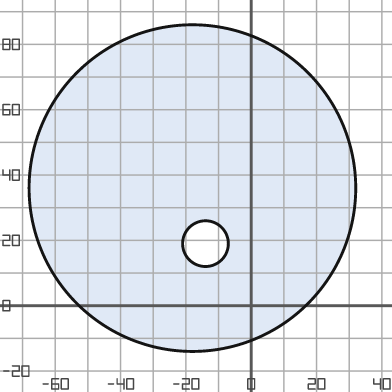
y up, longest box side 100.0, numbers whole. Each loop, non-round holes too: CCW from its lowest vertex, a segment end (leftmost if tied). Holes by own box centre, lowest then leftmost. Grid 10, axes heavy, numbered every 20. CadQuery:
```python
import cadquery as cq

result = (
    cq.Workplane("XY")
    .moveTo(-18.0, 36.0)
    .circle(50.0)
    .moveTo(-14.0, 19.0)
    .circle(7.0)
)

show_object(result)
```